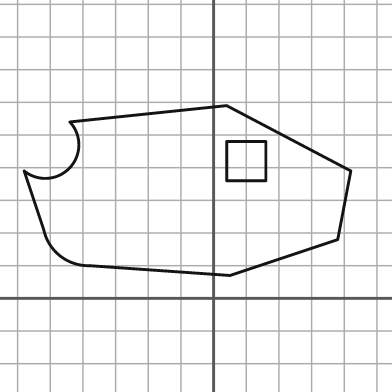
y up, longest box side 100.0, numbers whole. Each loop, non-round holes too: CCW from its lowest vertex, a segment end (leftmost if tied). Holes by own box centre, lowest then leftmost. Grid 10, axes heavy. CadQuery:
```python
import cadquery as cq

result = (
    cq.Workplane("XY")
    .moveTo(5.0, 7.0)
    .lineTo(38.0, 18.0)
    .lineTo(42.0, 39.0)
    .lineTo(4.0, 59.0)
    .lineTo(-44.0, 54.0)
    .threePointArc((-44.0, 40.0), (-58.0, 39.0))
    .lineTo(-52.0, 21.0)
    .threePointArc((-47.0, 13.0), (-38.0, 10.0))
    .close()
    .moveTo(4.0, 36.0)
    .lineTo(16.0, 36.0)
    .lineTo(16.0, 48.0)
    .lineTo(4.0, 48.0)
    .close()
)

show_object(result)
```